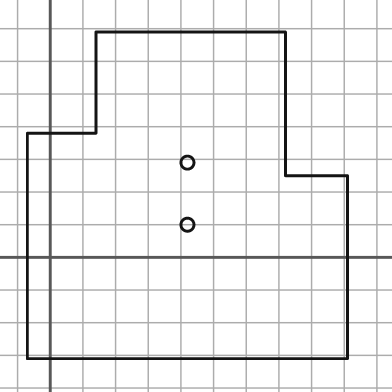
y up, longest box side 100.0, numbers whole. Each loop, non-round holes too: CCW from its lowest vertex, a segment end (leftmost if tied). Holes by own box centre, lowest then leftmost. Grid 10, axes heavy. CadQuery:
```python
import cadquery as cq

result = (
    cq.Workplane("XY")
    .moveTo(-7.0, -31.0)
    .lineTo(91.0, -31.0)
    .lineTo(91.0, 25.0)
    .lineTo(72.0, 25.0)
    .lineTo(72.0, 69.0)
    .lineTo(14.0, 69.0)
    .lineTo(14.0, 38.0)
    .lineTo(-7.0, 38.0)
    .close()
    .moveTo(42.0, 10.0)
    .circle(2.0)
    .moveTo(42.0, 29.0)
    .circle(2.0)
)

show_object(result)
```